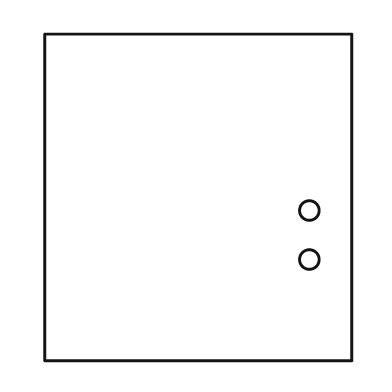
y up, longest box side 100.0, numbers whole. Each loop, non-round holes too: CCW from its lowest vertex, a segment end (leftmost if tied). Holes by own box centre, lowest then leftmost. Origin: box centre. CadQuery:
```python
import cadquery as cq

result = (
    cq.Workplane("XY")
    .moveTo(-47.0, -50.0)
    .lineTo(47.0, -50.0)
    .lineTo(47.0, 50.0)
    .lineTo(-47.0, 50.0)
    .close()
    .moveTo(34.0, -19.0)
    .circle(3.0)
    .moveTo(34.0, -4.0)
    .circle(3.0)
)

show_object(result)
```